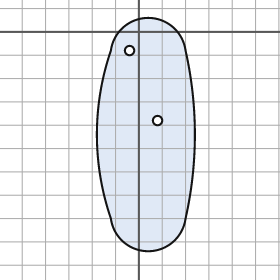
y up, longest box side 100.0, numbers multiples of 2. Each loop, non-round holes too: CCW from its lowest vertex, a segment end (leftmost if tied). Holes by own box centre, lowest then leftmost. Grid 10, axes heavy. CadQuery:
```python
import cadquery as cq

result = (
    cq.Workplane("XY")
    .moveTo(-12.0, -80.0)
    .threePointArc((4.0, -94.0), (20.0, -80.0))
    .threePointArc((24.0, -44.0), (20.0, -8.0))
    .threePointArc((4.0, 6.0), (-12.0, -8.0))
    .threePointArc((-18.0, -44.0), (-12.0, -80.0))
    .close()
    .moveTo(8.0, -38.0)
    .circle(2.0)
    .moveTo(-4.0, -8.0)
    .circle(2.0)
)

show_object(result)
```